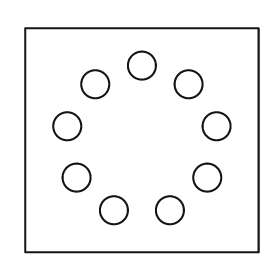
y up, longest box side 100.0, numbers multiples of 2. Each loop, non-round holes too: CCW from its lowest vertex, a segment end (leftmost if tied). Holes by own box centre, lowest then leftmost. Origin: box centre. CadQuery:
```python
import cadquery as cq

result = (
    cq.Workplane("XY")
    .moveTo(-50.0, -48.0)
    .lineTo(50.0, -48.0)
    .lineTo(50.0, 48.0)
    .lineTo(-50.0, 48.0)
    .close()
    .moveTo(-12.0, -30.0)
    .circle(6.0)
    .moveTo(12.0, -30.0)
    .circle(6.0)
    .moveTo(-28.0, -16.0)
    .circle(6.0)
    .moveTo(28.0, -16.0)
    .circle(6.0)
    .moveTo(-32.0, 6.0)
    .circle(6.0)
    .moveTo(32.0, 6.0)
    .circle(6.0)
    .moveTo(-20.0, 24.0)
    .circle(6.0)
    .moveTo(20.0, 24.0)
    .circle(6.0)
    .moveTo(0.0, 32.0)
    .circle(6.0)
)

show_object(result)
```